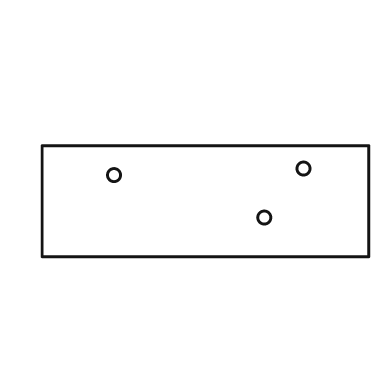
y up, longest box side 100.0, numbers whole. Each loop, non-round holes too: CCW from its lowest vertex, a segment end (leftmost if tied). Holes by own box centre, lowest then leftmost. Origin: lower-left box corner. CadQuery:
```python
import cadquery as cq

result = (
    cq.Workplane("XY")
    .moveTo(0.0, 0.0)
    .lineTo(100.0, 0.0)
    .lineTo(100.0, 34.0)
    .lineTo(0.0, 34.0)
    .close()
    .moveTo(68.0, 12.0)
    .circle(2.0)
    .moveTo(22.0, 25.0)
    .circle(2.0)
    .moveTo(80.0, 27.0)
    .circle(2.0)
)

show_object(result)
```